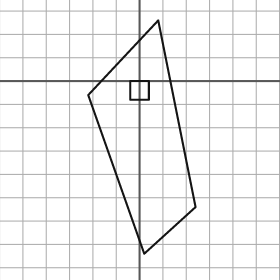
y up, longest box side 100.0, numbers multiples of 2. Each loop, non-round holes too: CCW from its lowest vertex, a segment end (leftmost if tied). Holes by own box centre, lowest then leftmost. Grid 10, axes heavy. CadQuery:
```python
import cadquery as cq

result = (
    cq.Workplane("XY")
    .moveTo(2.0, -74.0)
    .lineTo(24.0, -54.0)
    .lineTo(8.0, 26.0)
    .lineTo(-22.0, -6.0)
    .close()
    .moveTo(-4.0, -8.0)
    .lineTo(4.0, -8.0)
    .lineTo(4.0, 0.0)
    .lineTo(-4.0, 0.0)
    .close()
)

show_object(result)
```